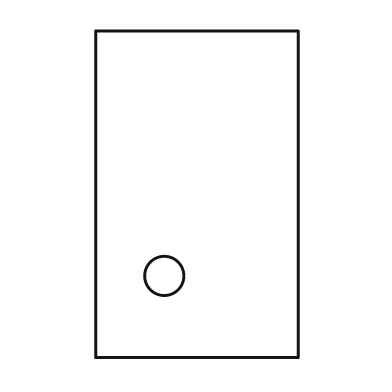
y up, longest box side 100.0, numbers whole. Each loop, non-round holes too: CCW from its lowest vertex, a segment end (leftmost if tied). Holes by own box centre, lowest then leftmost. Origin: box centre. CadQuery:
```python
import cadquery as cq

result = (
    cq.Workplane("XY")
    .moveTo(-31.0, -50.0)
    .lineTo(31.0, -50.0)
    .lineTo(31.0, 50.0)
    .lineTo(-31.0, 50.0)
    .close()
    .moveTo(-10.0, -25.0)
    .circle(6.0)
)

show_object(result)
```